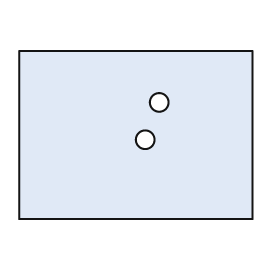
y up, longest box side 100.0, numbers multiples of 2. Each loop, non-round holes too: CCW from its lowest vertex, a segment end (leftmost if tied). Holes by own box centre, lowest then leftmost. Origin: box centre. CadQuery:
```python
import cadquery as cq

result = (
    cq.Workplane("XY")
    .moveTo(-50.0, -36.0)
    .lineTo(50.0, -36.0)
    .lineTo(50.0, 36.0)
    .lineTo(-50.0, 36.0)
    .close()
    .moveTo(4.0, -2.0)
    .circle(4.0)
    .moveTo(10.0, 14.0)
    .circle(4.0)
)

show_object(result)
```